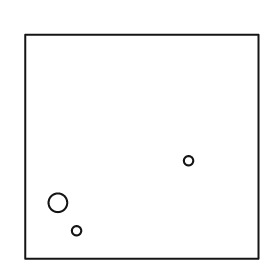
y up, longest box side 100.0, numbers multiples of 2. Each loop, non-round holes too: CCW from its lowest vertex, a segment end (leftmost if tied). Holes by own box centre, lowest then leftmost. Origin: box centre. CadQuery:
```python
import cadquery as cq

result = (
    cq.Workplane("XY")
    .moveTo(-50.0, -48.0)
    .lineTo(50.0, -48.0)
    .lineTo(50.0, 48.0)
    .lineTo(-50.0, 48.0)
    .close()
    .moveTo(-28.0, -36.0)
    .circle(2.0)
    .moveTo(-36.0, -24.0)
    .circle(4.0)
    .moveTo(20.0, -6.0)
    .circle(2.0)
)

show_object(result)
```